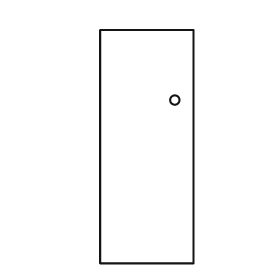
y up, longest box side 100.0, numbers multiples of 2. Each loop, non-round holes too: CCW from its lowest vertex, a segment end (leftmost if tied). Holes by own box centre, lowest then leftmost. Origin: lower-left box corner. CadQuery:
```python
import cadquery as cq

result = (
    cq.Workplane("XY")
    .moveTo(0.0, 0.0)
    .lineTo(40.0, 0.0)
    .lineTo(40.0, 100.0)
    .lineTo(0.0, 100.0)
    .close()
    .moveTo(32.0, 70.0)
    .circle(2.0)
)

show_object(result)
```